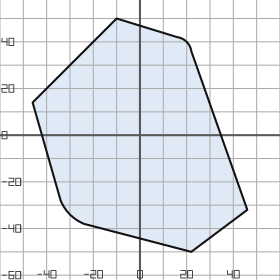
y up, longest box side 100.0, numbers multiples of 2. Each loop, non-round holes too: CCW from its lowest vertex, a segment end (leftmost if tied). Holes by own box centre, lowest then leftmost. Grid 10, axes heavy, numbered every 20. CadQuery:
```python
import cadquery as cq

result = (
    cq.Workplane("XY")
    .moveTo(22.0, -50.0)
    .lineTo(46.0, -32.0)
    .lineTo(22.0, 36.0)
    .threePointArc((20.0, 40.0), (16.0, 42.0))
    .lineTo(-10.0, 50.0)
    .lineTo(-46.0, 14.0)
    .lineTo(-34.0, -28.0)
    .threePointArc((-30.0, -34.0), (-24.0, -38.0))
    .close()
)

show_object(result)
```